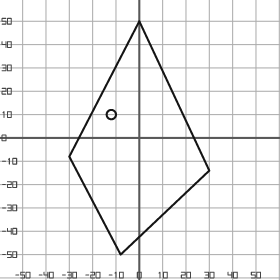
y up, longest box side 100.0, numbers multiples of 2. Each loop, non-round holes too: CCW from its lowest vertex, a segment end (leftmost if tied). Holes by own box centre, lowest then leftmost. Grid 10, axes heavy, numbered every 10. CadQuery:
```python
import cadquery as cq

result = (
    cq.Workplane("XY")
    .moveTo(-8.0, -50.0)
    .lineTo(30.0, -14.0)
    .lineTo(0.0, 50.0)
    .lineTo(-30.0, -8.0)
    .close()
    .moveTo(-12.0, 10.0)
    .circle(2.0)
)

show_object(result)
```